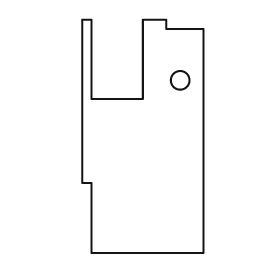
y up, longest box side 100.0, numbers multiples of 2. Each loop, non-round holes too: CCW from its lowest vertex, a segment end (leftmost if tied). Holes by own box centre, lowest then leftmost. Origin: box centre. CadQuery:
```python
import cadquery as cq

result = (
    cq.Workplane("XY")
    .moveTo(-22.0, -50.0)
    .lineTo(26.0, -50.0)
    .lineTo(26.0, 46.0)
    .lineTo(10.0, 46.0)
    .lineTo(10.0, 50.0)
    .lineTo(0.0, 50.0)
    .lineTo(0.0, 16.0)
    .lineTo(-22.0, 16.0)
    .lineTo(-22.0, 50.0)
    .lineTo(-26.0, 50.0)
    .lineTo(-26.0, -20.0)
    .lineTo(-22.0, -20.0)
    .close()
    .moveTo(16.0, 24.0)
    .circle(4.0)
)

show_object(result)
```